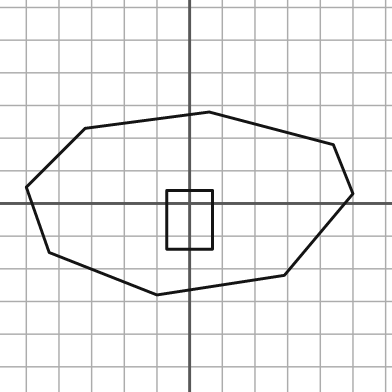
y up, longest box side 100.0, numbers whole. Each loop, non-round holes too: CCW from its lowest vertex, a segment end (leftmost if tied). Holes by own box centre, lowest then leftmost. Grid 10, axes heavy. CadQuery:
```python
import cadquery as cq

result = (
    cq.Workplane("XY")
    .moveTo(-10.0, -28.0)
    .lineTo(29.0, -22.0)
    .lineTo(50.0, 3.0)
    .lineTo(44.0, 18.0)
    .lineTo(6.0, 28.0)
    .lineTo(-32.0, 23.0)
    .lineTo(-50.0, 5.0)
    .lineTo(-43.0, -15.0)
    .close()
    .moveTo(-7.0, -14.0)
    .lineTo(7.0, -14.0)
    .lineTo(7.0, 4.0)
    .lineTo(-7.0, 4.0)
    .close()
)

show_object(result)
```